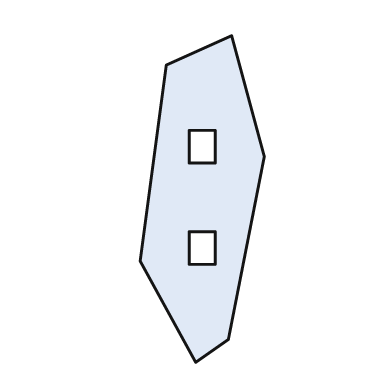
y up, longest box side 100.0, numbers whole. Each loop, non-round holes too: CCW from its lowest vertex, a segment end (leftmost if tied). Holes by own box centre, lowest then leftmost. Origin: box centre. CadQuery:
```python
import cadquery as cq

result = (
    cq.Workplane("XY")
    .moveTo(-2.0, -50.0)
    .lineTo(8.0, -43.0)
    .lineTo(19.0, 13.0)
    .lineTo(9.0, 50.0)
    .lineTo(-11.0, 41.0)
    .lineTo(-19.0, -19.0)
    .close()
    .moveTo(-4.0, -20.0)
    .lineTo(4.0, -20.0)
    .lineTo(4.0, -10.0)
    .lineTo(-4.0, -10.0)
    .close()
    .moveTo(-4.0, 11.0)
    .lineTo(4.0, 11.0)
    .lineTo(4.0, 21.0)
    .lineTo(-4.0, 21.0)
    .close()
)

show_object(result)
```